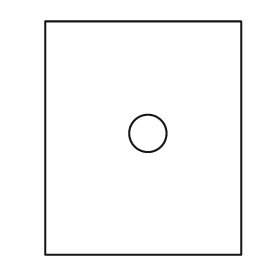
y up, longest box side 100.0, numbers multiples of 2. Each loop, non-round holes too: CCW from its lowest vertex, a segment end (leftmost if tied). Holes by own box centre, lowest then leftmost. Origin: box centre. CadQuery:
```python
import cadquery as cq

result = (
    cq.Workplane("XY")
    .moveTo(-42.0, -50.0)
    .lineTo(42.0, -50.0)
    .lineTo(42.0, 50.0)
    .lineTo(-42.0, 50.0)
    .close()
    .moveTo(2.0, 2.0)
    .circle(8.0)
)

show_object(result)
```